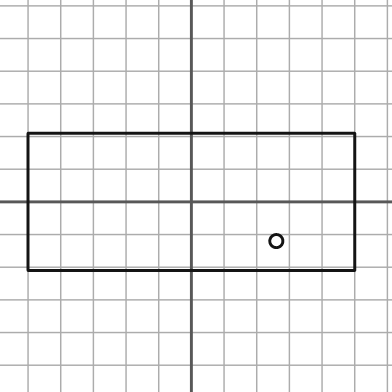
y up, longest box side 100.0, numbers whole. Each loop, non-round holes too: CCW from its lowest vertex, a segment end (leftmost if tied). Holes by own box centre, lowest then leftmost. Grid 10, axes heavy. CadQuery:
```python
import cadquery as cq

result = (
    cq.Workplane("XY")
    .moveTo(-50.0, -21.0)
    .lineTo(50.0, -21.0)
    .lineTo(50.0, 21.0)
    .lineTo(-50.0, 21.0)
    .close()
    .moveTo(26.0, -12.0)
    .circle(2.0)
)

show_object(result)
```